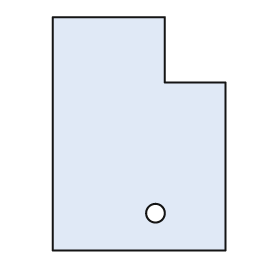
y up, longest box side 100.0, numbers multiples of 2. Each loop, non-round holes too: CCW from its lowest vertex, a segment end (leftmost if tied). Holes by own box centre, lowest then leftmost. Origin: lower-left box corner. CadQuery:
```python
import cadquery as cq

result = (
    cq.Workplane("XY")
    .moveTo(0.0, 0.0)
    .lineTo(74.0, 0.0)
    .lineTo(74.0, 72.0)
    .lineTo(48.0, 72.0)
    .lineTo(48.0, 100.0)
    .lineTo(0.0, 100.0)
    .close()
    .moveTo(44.0, 16.0)
    .circle(4.0)
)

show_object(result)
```